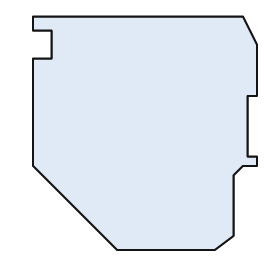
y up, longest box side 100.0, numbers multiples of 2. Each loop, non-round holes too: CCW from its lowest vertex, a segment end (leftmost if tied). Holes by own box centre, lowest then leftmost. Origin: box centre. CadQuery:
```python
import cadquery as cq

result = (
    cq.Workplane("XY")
    .moveTo(-12.0, -50.0)
    .lineTo(30.0, -50.0)
    .lineTo(38.0, -44.0)
    .lineTo(38.0, -18.0)
    .lineTo(42.0, -14.0)
    .lineTo(48.0, -14.0)
    .lineTo(48.0, -10.0)
    .lineTo(44.0, -10.0)
    .lineTo(44.0, 16.0)
    .lineTo(48.0, 16.0)
    .lineTo(48.0, 38.0)
    .lineTo(42.0, 50.0)
    .lineTo(-48.0, 50.0)
    .lineTo(-48.0, 44.0)
    .lineTo(-40.0, 44.0)
    .lineTo(-40.0, 32.0)
    .lineTo(-48.0, 32.0)
    .lineTo(-48.0, -14.0)
    .close()
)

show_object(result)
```